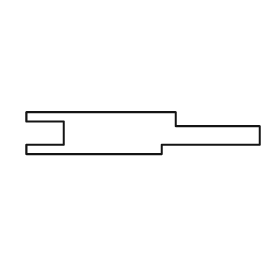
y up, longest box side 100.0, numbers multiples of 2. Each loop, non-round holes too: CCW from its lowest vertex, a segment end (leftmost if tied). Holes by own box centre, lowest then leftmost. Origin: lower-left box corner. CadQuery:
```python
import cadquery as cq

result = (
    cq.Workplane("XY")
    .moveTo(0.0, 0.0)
    .lineTo(58.0, 0.0)
    .lineTo(58.0, 4.0)
    .lineTo(100.0, 4.0)
    .lineTo(100.0, 12.0)
    .lineTo(64.0, 12.0)
    .lineTo(64.0, 18.0)
    .lineTo(0.0, 18.0)
    .lineTo(0.0, 14.0)
    .lineTo(16.0, 14.0)
    .lineTo(16.0, 4.0)
    .lineTo(0.0, 4.0)
    .close()
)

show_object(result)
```